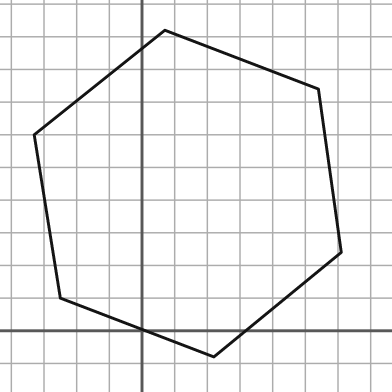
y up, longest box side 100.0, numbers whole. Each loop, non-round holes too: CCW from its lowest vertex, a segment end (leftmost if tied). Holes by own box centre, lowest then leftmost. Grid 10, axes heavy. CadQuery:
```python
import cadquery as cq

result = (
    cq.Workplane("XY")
    .moveTo(22.0, -8.0)
    .lineTo(61.0, 24.0)
    .lineTo(54.0, 74.0)
    .lineTo(7.0, 92.0)
    .lineTo(-33.0, 60.0)
    .lineTo(-25.0, 10.0)
    .close()
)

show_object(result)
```